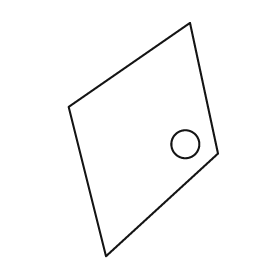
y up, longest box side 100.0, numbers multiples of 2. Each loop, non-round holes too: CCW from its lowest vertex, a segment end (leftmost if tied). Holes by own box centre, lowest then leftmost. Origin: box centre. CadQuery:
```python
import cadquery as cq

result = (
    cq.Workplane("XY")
    .moveTo(-16.0, -50.0)
    .lineTo(32.0, -6.0)
    .lineTo(20.0, 50.0)
    .lineTo(-32.0, 14.0)
    .close()
    .moveTo(18.0, -2.0)
    .circle(6.0)
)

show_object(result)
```